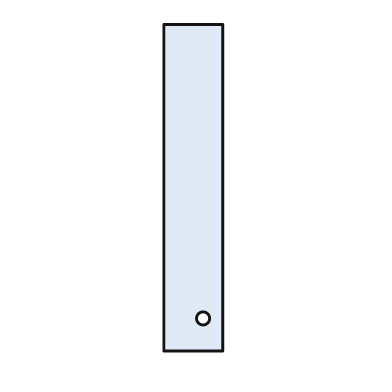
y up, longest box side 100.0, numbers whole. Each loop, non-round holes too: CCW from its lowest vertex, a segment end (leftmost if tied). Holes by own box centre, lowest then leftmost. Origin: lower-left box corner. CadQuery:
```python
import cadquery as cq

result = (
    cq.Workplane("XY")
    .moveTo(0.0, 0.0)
    .lineTo(18.0, 0.0)
    .lineTo(18.0, 100.0)
    .lineTo(0.0, 100.0)
    .close()
    .moveTo(12.0, 10.0)
    .circle(2.0)
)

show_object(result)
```